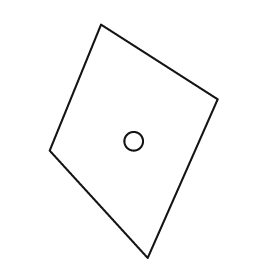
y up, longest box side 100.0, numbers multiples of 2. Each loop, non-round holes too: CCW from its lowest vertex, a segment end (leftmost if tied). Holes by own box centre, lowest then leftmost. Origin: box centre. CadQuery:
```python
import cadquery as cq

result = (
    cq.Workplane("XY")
    .moveTo(6.0, -50.0)
    .lineTo(36.0, 18.0)
    .lineTo(-14.0, 50.0)
    .lineTo(-36.0, -4.0)
    .close()
    .moveTo(0.0, 0.0)
    .circle(4.0)
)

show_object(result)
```